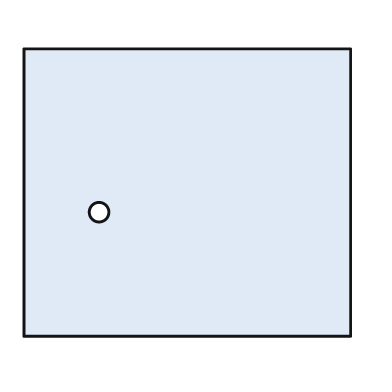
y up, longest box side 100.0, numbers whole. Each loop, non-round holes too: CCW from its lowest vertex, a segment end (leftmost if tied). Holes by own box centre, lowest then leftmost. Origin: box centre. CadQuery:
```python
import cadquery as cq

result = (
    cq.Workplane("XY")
    .moveTo(-50.0, -44.0)
    .lineTo(50.0, -44.0)
    .lineTo(50.0, 44.0)
    .lineTo(-50.0, 44.0)
    .close()
    .moveTo(-27.0, -6.0)
    .circle(3.0)
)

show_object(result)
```